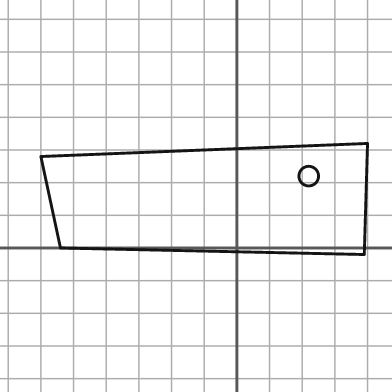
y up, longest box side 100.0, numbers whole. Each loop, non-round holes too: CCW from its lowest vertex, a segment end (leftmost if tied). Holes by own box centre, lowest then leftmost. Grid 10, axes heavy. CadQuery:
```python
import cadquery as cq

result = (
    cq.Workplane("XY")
    .moveTo(39.0, -2.0)
    .lineTo(40.0, 32.0)
    .lineTo(-60.0, 28.0)
    .lineTo(-54.0, 0.0)
    .close()
    .moveTo(22.0, 22.0)
    .circle(3.0)
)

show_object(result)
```